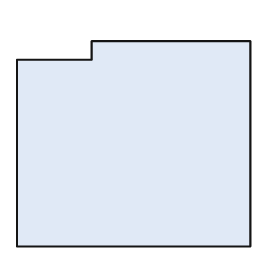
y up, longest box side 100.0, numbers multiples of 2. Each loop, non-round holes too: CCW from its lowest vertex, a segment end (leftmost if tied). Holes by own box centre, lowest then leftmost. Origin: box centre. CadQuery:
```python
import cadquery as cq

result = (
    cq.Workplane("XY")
    .moveTo(-50.0, -44.0)
    .lineTo(50.0, -44.0)
    .lineTo(50.0, 44.0)
    .lineTo(-18.0, 44.0)
    .lineTo(-18.0, 36.0)
    .lineTo(-50.0, 36.0)
    .close()
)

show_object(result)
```